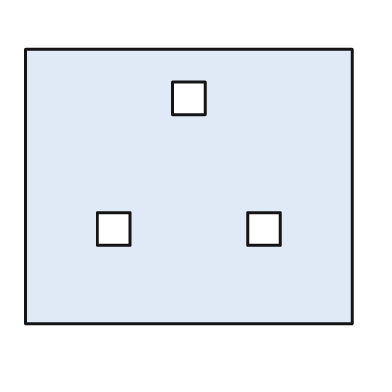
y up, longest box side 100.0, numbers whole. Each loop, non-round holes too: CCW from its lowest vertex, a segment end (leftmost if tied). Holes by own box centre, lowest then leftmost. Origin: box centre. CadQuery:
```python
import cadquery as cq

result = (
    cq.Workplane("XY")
    .moveTo(-50.0, -42.0)
    .lineTo(50.0, -42.0)
    .lineTo(50.0, 42.0)
    .lineTo(-50.0, 42.0)
    .close()
    .moveTo(-28.0, -18.0)
    .lineTo(-18.0, -18.0)
    .lineTo(-18.0, -8.0)
    .lineTo(-28.0, -8.0)
    .close()
    .moveTo(18.0, -18.0)
    .lineTo(28.0, -18.0)
    .lineTo(28.0, -8.0)
    .lineTo(18.0, -8.0)
    .close()
    .moveTo(-5.0, 22.0)
    .lineTo(5.0, 22.0)
    .lineTo(5.0, 32.0)
    .lineTo(-5.0, 32.0)
    .close()
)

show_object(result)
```